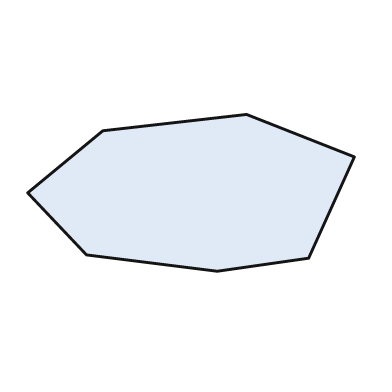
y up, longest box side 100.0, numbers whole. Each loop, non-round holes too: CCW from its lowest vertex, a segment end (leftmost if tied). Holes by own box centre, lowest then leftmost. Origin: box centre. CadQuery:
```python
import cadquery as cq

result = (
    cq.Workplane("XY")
    .moveTo(8.0, -24.0)
    .lineTo(36.0, -20.0)
    .lineTo(50.0, 11.0)
    .lineTo(17.0, 24.0)
    .lineTo(-27.0, 19.0)
    .lineTo(-50.0, 0.0)
    .lineTo(-32.0, -19.0)
    .close()
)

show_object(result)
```